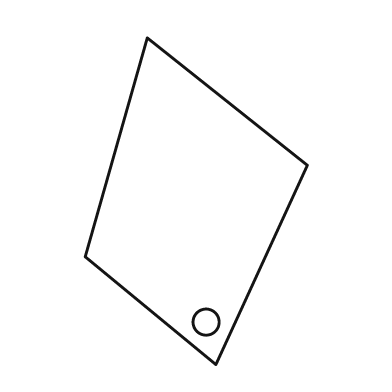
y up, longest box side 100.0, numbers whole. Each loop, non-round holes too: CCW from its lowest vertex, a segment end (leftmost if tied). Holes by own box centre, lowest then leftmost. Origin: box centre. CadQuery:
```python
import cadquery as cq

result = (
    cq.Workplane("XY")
    .moveTo(6.0, -50.0)
    .lineTo(34.0, 11.0)
    .lineTo(-15.0, 50.0)
    .lineTo(-34.0, -17.0)
    .close()
    .moveTo(3.0, -37.0)
    .circle(4.0)
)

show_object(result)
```